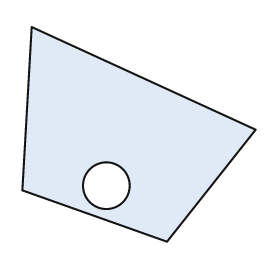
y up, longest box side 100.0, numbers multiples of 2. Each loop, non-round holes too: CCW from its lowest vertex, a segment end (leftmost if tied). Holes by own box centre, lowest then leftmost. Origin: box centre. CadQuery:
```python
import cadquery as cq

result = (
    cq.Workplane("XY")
    .moveTo(12.0, -46.0)
    .lineTo(50.0, 2.0)
    .lineTo(-46.0, 46.0)
    .lineTo(-50.0, -24.0)
    .close()
    .moveTo(-14.0, -22.0)
    .circle(10.0)
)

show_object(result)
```